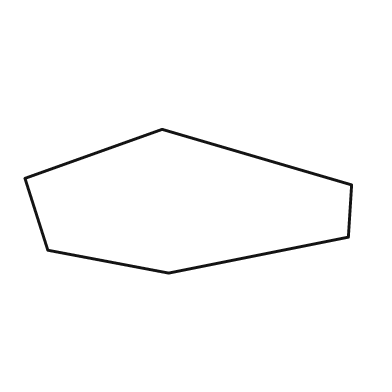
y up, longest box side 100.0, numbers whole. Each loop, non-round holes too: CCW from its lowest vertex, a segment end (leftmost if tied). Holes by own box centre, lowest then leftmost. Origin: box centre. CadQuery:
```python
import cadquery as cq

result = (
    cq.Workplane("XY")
    .moveTo(-6.0, -22.0)
    .lineTo(49.0, -11.0)
    .lineTo(50.0, 5.0)
    .lineTo(-8.0, 22.0)
    .lineTo(-50.0, 7.0)
    .lineTo(-43.0, -15.0)
    .close()
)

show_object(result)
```